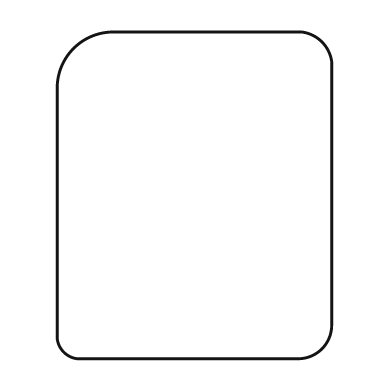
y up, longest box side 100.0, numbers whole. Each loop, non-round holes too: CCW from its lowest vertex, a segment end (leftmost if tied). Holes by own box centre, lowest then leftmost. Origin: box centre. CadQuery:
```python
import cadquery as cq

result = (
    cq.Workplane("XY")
    .moveTo(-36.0, -50.0)
    .lineTo(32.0, -50.0)
    .threePointArc((39.0, -47.0), (42.0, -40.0))
    .lineTo(42.0, 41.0)
    .threePointArc((39.0, 47.0), (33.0, 50.0))
    .lineTo(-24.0, 50.0)
    .threePointArc((-37.0, 45.0), (-42.0, 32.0))
    .lineTo(-42.0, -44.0)
    .threePointArc((-40.0, -48.0), (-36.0, -50.0))
    .close()
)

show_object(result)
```